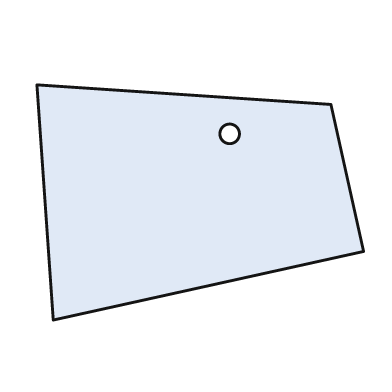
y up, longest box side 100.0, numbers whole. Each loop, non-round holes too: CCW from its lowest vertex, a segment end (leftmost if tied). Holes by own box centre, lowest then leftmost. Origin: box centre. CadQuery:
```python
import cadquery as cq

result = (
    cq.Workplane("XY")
    .moveTo(-45.0, -36.0)
    .lineTo(50.0, -15.0)
    .lineTo(40.0, 30.0)
    .lineTo(-50.0, 36.0)
    .close()
    .moveTo(9.0, 21.0)
    .circle(3.0)
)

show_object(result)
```